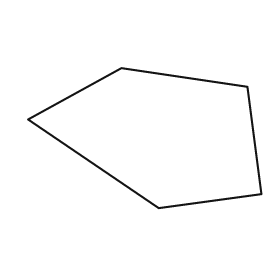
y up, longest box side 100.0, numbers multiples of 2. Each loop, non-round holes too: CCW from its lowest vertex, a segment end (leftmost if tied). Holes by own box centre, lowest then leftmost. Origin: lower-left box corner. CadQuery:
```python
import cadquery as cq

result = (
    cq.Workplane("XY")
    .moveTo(56.0, 0.0)
    .lineTo(100.0, 6.0)
    .lineTo(94.0, 52.0)
    .lineTo(40.0, 60.0)
    .lineTo(0.0, 38.0)
    .close()
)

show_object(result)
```